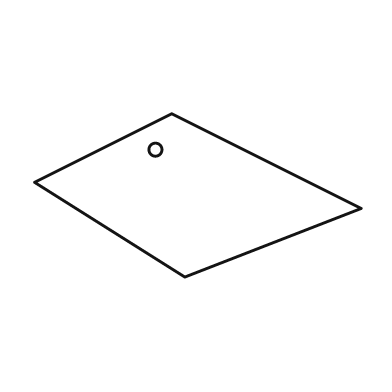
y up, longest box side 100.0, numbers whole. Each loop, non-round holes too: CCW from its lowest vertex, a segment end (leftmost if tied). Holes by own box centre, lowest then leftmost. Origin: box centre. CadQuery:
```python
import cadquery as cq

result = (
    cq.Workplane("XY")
    .moveTo(-4.0, -25.0)
    .lineTo(50.0, -4.0)
    .lineTo(-8.0, 25.0)
    .lineTo(-50.0, 4.0)
    .close()
    .moveTo(-13.0, 14.0)
    .circle(2.0)
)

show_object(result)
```